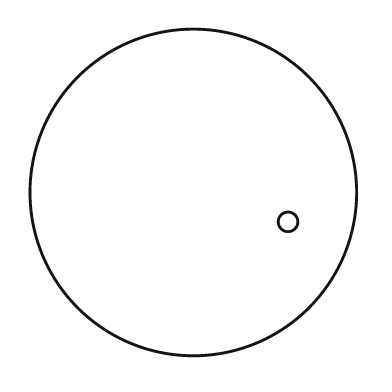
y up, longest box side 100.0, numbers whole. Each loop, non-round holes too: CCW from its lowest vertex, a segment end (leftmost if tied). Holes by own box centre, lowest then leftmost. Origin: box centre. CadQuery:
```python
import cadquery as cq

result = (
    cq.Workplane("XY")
    .moveTo(0.0, 0.0)
    .circle(50.0)
    .moveTo(29.0, -9.0)
    .circle(3.0)
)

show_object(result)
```